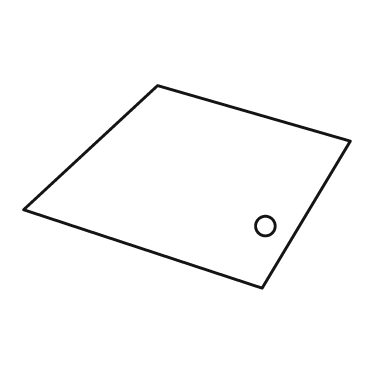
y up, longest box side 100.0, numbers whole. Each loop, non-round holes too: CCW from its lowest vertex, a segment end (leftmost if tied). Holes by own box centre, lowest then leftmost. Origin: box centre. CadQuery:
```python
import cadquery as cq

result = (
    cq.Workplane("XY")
    .moveTo(23.0, -31.0)
    .lineTo(50.0, 14.0)
    .lineTo(-9.0, 31.0)
    .lineTo(-50.0, -7.0)
    .close()
    .moveTo(24.0, -12.0)
    .circle(3.0)
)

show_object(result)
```